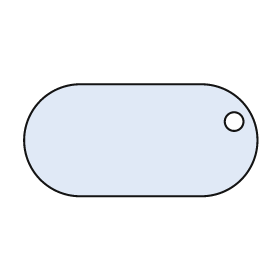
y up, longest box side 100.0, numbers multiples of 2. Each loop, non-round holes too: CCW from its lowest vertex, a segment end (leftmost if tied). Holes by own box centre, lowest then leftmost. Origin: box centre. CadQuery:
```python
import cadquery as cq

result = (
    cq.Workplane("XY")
    .moveTo(-26.0, -24.0)
    .lineTo(26.0, -24.0)
    .threePointArc((50.0, 0.0), (26.0, 24.0))
    .lineTo(-26.0, 24.0)
    .threePointArc((-50.0, 0.0), (-26.0, -24.0))
    .close()
    .moveTo(40.0, 8.0)
    .circle(4.0)
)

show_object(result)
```